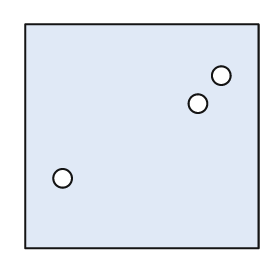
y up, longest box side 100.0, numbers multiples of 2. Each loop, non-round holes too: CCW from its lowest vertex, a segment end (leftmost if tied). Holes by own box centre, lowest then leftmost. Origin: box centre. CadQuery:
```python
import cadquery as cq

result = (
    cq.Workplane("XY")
    .moveTo(-50.0, -48.0)
    .lineTo(50.0, -48.0)
    .lineTo(50.0, 48.0)
    .lineTo(-50.0, 48.0)
    .close()
    .moveTo(-34.0, -18.0)
    .circle(4.0)
    .moveTo(24.0, 14.0)
    .circle(4.0)
    .moveTo(34.0, 26.0)
    .circle(4.0)
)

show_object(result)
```